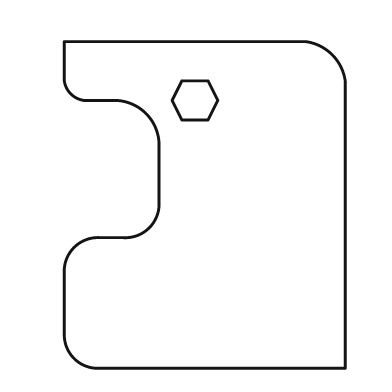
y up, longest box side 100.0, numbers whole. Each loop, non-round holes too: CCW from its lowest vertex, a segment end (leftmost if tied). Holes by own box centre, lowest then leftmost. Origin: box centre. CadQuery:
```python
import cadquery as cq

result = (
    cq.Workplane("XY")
    .moveTo(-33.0, -50.0)
    .lineTo(43.0, -50.0)
    .lineTo(43.0, 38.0)
    .threePointArc((39.0, 46.0), (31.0, 50.0))
    .lineTo(-43.0, 50.0)
    .lineTo(-43.0, 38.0)
    .threePointArc((-41.0, 34.0), (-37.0, 32.0))
    .lineTo(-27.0, 32.0)
    .threePointArc((-18.0, 28.0), (-14.0, 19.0))
    .lineTo(-14.0, 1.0)
    .threePointArc((-17.0, -7.0), (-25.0, -10.0))
    .lineTo(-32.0, -10.0)
    .threePointArc((-40.0, -13.0), (-43.0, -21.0))
    .lineTo(-43.0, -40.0)
    .threePointArc((-40.0, -47.0), (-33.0, -50.0))
    .close()
    .moveTo(-7.0, 26.0)
    .lineTo(1.0, 26.0)
    .lineTo(4.0, 32.0)
    .lineTo(1.0, 38.0)
    .lineTo(-7.0, 38.0)
    .lineTo(-10.0, 32.0)
    .close()
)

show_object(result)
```